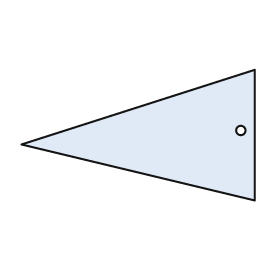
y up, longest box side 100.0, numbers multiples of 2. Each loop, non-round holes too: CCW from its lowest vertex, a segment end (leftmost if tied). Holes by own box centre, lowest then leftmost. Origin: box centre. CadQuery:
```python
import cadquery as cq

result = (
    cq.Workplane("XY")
    .moveTo(50.0, -28.0)
    .lineTo(50.0, 28.0)
    .lineTo(-50.0, -4.0)
    .close()
    .moveTo(44.0, 2.0)
    .circle(2.0)
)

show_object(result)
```